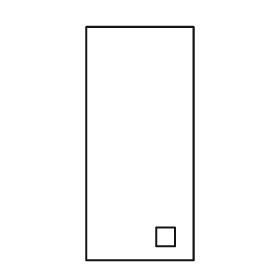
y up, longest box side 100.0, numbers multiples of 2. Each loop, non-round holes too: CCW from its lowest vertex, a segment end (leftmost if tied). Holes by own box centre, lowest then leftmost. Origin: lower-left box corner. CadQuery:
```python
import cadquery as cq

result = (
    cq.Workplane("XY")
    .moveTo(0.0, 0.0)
    .lineTo(46.0, 0.0)
    .lineTo(46.0, 100.0)
    .lineTo(0.0, 100.0)
    .close()
    .moveTo(30.0, 6.0)
    .lineTo(38.0, 6.0)
    .lineTo(38.0, 14.0)
    .lineTo(30.0, 14.0)
    .close()
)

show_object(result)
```